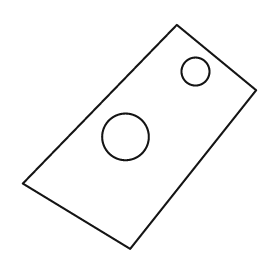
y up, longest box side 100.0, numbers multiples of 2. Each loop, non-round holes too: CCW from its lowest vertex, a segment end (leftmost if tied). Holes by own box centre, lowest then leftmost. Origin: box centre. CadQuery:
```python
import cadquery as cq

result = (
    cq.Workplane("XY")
    .moveTo(-4.0, -48.0)
    .lineTo(50.0, 20.0)
    .lineTo(16.0, 48.0)
    .lineTo(-50.0, -20.0)
    .close()
    .moveTo(-6.0, 0.0)
    .circle(10.0)
    .moveTo(24.0, 28.0)
    .circle(6.0)
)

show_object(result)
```